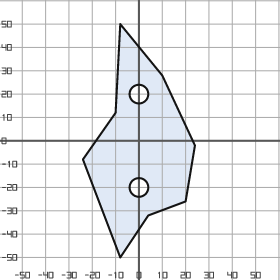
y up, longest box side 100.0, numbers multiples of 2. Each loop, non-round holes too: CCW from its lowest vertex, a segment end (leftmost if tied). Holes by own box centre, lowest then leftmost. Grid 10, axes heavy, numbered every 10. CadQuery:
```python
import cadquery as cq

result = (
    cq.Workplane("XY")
    .moveTo(-8.0, -50.0)
    .lineTo(4.0, -32.0)
    .lineTo(20.0, -26.0)
    .lineTo(24.0, -2.0)
    .lineTo(10.0, 28.0)
    .lineTo(-8.0, 50.0)
    .lineTo(-10.0, 12.0)
    .lineTo(-24.0, -8.0)
    .close()
    .moveTo(0.0, -20.0)
    .circle(4.0)
    .moveTo(0.0, 20.0)
    .circle(4.0)
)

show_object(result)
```